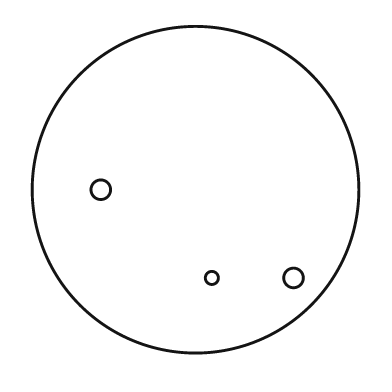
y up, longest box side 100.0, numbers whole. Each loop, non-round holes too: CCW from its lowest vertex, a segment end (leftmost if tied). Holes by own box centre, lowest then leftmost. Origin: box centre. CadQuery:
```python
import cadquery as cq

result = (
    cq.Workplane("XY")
    .moveTo(0.0, 0.0)
    .circle(50.0)
    .moveTo(5.0, -27.0)
    .circle(2.0)
    .moveTo(30.0, -27.0)
    .circle(3.0)
    .moveTo(-29.0, 0.0)
    .circle(3.0)
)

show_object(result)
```